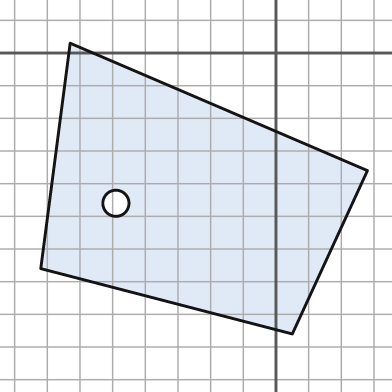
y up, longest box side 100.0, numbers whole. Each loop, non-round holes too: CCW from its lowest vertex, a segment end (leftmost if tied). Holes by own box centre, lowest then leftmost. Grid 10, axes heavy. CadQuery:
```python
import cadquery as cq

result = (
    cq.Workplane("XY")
    .moveTo(5.0, -86.0)
    .lineTo(28.0, -36.0)
    .lineTo(-63.0, 3.0)
    .lineTo(-72.0, -66.0)
    .close()
    .moveTo(-49.0, -46.0)
    .circle(4.0)
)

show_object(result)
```